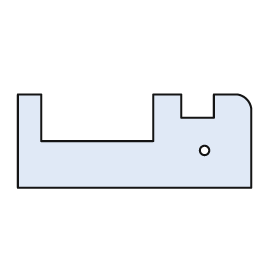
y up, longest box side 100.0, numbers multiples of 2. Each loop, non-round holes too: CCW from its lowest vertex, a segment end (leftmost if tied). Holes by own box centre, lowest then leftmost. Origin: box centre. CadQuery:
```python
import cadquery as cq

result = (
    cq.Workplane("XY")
    .moveTo(-50.0, -20.0)
    .lineTo(50.0, -20.0)
    .lineTo(50.0, 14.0)
    .threePointArc((48.0, 18.0), (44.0, 20.0))
    .lineTo(34.0, 20.0)
    .lineTo(34.0, 10.0)
    .lineTo(20.0, 10.0)
    .lineTo(20.0, 20.0)
    .lineTo(8.0, 20.0)
    .lineTo(8.0, 0.0)
    .lineTo(-40.0, 0.0)
    .lineTo(-40.0, 20.0)
    .lineTo(-50.0, 20.0)
    .close()
    .moveTo(30.0, -4.0)
    .circle(2.0)
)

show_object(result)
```